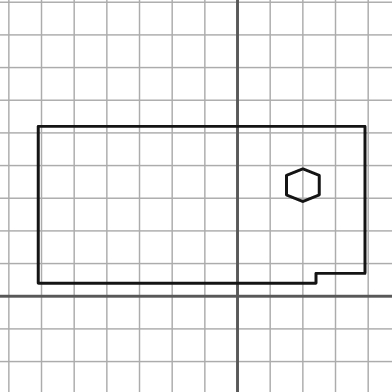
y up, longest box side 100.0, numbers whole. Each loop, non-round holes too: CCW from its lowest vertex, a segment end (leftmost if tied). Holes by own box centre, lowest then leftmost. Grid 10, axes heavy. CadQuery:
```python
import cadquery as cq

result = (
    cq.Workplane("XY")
    .moveTo(-61.0, 4.0)
    .lineTo(24.0, 4.0)
    .lineTo(24.0, 7.0)
    .lineTo(39.0, 7.0)
    .lineTo(39.0, 52.0)
    .lineTo(-61.0, 52.0)
    .close()
    .moveTo(20.0, 29.0)
    .lineTo(25.0, 31.0)
    .lineTo(25.0, 37.0)
    .lineTo(20.0, 39.0)
    .lineTo(15.0, 37.0)
    .lineTo(15.0, 31.0)
    .close()
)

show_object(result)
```